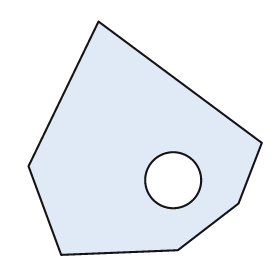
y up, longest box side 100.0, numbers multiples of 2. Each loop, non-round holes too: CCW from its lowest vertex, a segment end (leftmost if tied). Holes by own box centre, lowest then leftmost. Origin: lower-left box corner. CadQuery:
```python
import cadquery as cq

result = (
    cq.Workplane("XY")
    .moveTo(14.0, 0.0)
    .lineTo(64.0, 2.0)
    .lineTo(90.0, 22.0)
    .lineTo(100.0, 48.0)
    .lineTo(30.0, 100.0)
    .lineTo(0.0, 38.0)
    .close()
    .moveTo(62.0, 32.0)
    .circle(12.0)
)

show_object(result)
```